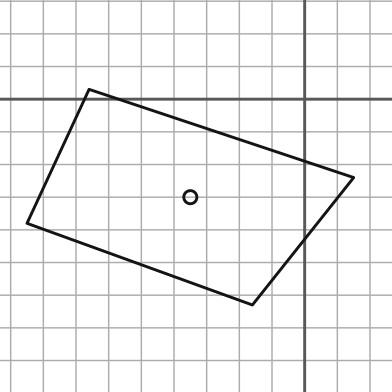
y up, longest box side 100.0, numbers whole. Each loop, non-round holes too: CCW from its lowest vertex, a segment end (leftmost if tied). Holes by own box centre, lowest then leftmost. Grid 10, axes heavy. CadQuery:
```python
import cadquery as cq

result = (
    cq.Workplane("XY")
    .moveTo(-16.0, -63.0)
    .lineTo(15.0, -24.0)
    .lineTo(-66.0, 3.0)
    .lineTo(-85.0, -38.0)
    .close()
    .moveTo(-35.0, -30.0)
    .circle(2.0)
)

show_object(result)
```